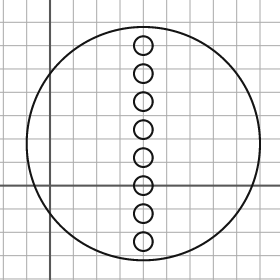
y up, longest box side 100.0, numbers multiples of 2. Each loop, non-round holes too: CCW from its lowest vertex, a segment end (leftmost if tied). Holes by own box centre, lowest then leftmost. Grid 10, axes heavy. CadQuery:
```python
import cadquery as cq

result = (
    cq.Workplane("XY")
    .moveTo(40.0, 18.0)
    .circle(50.0)
    .moveTo(40.0, -24.0)
    .circle(4.0)
    .moveTo(40.0, -12.0)
    .circle(4.0)
    .moveTo(40.0, 0.0)
    .circle(4.0)
    .moveTo(40.0, 12.0)
    .circle(4.0)
    .moveTo(40.0, 24.0)
    .circle(4.0)
    .moveTo(40.0, 36.0)
    .circle(4.0)
    .moveTo(40.0, 48.0)
    .circle(4.0)
    .moveTo(40.0, 60.0)
    .circle(4.0)
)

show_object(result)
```